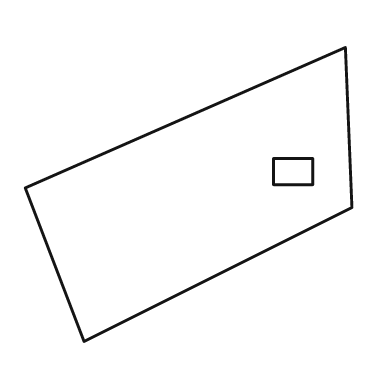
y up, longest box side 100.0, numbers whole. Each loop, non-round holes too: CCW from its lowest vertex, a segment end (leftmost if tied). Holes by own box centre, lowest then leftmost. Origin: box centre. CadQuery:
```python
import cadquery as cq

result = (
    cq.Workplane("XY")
    .moveTo(-32.0, -45.0)
    .lineTo(50.0, -4.0)
    .lineTo(48.0, 45.0)
    .lineTo(-50.0, 2.0)
    .close()
    .moveTo(26.0, 3.0)
    .lineTo(38.0, 3.0)
    .lineTo(38.0, 11.0)
    .lineTo(26.0, 11.0)
    .close()
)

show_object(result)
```